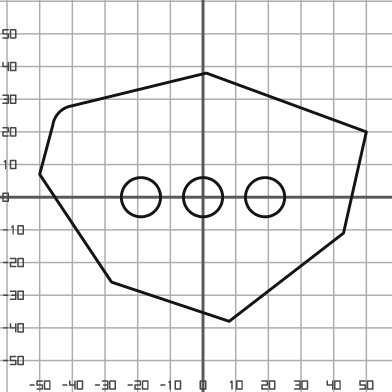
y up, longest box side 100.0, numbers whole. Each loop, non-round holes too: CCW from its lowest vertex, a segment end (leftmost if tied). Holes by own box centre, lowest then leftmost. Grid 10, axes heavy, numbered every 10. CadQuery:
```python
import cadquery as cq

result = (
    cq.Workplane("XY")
    .moveTo(8.0, -38.0)
    .lineTo(43.0, -11.0)
    .lineTo(50.0, 20.0)
    .lineTo(1.0, 38.0)
    .lineTo(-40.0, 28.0)
    .threePointArc((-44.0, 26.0), (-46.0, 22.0))
    .lineTo(-50.0, 7.0)
    .lineTo(-28.0, -26.0)
    .close()
    .moveTo(-19.0, 0.0)
    .circle(6.0)
    .moveTo(0.0, 0.0)
    .circle(6.0)
    .moveTo(19.0, 0.0)
    .circle(6.0)
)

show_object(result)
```